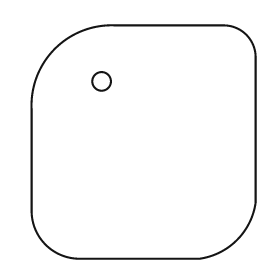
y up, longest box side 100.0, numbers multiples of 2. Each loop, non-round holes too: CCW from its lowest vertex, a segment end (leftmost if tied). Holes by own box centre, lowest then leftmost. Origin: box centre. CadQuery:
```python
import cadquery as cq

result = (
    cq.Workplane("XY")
    .moveTo(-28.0, -50.0)
    .lineTo(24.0, -50.0)
    .threePointArc((40.0, -42.0), (48.0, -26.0))
    .lineTo(48.0, 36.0)
    .threePointArc((44.0, 46.0), (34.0, 50.0))
    .lineTo(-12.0, 50.0)
    .threePointArc((-38.0, 40.0), (-48.0, 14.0))
    .lineTo(-48.0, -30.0)
    .threePointArc((-42.0, -44.0), (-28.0, -50.0))
    .close()
    .moveTo(-18.0, 26.0)
    .circle(4.0)
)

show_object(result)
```